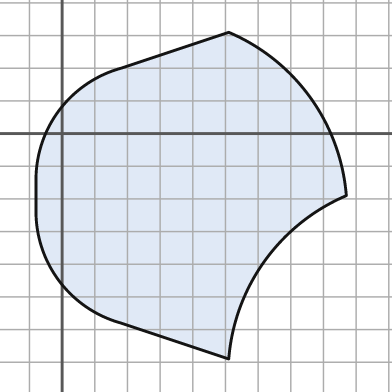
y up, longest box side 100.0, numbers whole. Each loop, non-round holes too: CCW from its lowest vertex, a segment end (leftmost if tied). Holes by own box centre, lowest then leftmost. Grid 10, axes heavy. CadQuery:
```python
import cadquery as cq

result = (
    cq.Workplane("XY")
    .moveTo(51.0, -69.0)
    .threePointArc((62.0, -39.0), (87.0, -19.0))
    .threePointArc((76.0, 11.0), (51.0, 31.0))
    .lineTo(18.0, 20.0)
    .threePointArc((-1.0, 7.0), (-8.0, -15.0))
    .lineTo(-8.0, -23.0)
    .threePointArc((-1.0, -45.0), (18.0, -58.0))
    .close()
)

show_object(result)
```